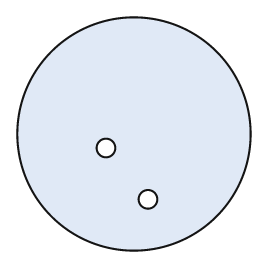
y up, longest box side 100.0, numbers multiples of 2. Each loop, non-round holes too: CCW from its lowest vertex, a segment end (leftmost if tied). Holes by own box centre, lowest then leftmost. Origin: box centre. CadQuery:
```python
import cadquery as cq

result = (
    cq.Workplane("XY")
    .moveTo(0.0, 0.0)
    .circle(50.0)
    .moveTo(6.0, -28.0)
    .circle(4.0)
    .moveTo(-12.0, -6.0)
    .circle(4.0)
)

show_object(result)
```